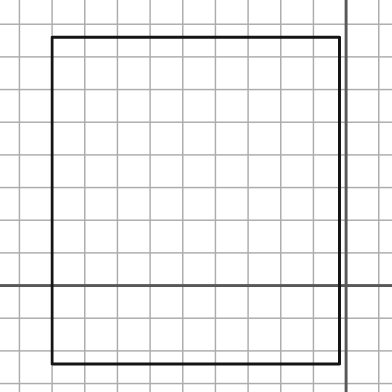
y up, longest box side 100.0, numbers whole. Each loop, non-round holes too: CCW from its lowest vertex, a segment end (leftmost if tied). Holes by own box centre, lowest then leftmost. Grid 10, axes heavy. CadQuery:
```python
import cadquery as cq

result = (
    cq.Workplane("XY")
    .moveTo(-90.0, -24.0)
    .lineTo(-2.0, -24.0)
    .lineTo(-2.0, 76.0)
    .lineTo(-90.0, 76.0)
    .close()
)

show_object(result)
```